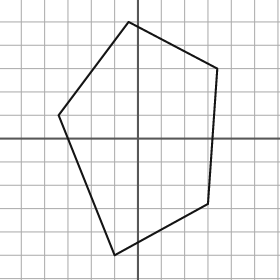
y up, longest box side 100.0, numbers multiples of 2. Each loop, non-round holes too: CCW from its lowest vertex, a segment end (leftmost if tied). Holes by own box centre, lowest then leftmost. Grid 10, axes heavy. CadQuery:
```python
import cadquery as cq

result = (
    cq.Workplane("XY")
    .moveTo(-10.0, -50.0)
    .lineTo(30.0, -28.0)
    .lineTo(34.0, 30.0)
    .lineTo(-4.0, 50.0)
    .lineTo(-34.0, 10.0)
    .close()
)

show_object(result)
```